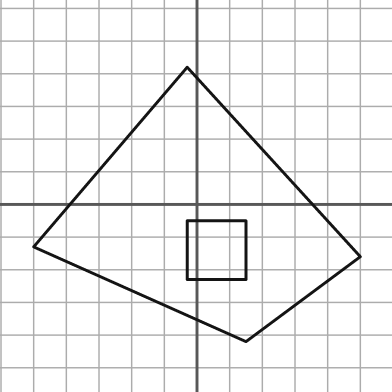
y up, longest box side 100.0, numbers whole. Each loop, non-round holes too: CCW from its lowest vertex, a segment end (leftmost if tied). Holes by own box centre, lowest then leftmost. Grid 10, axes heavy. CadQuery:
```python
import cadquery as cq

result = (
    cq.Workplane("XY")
    .moveTo(15.0, -42.0)
    .lineTo(50.0, -16.0)
    .lineTo(-3.0, 42.0)
    .lineTo(-50.0, -13.0)
    .close()
    .moveTo(-3.0, -23.0)
    .lineTo(15.0, -23.0)
    .lineTo(15.0, -5.0)
    .lineTo(-3.0, -5.0)
    .close()
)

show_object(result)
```